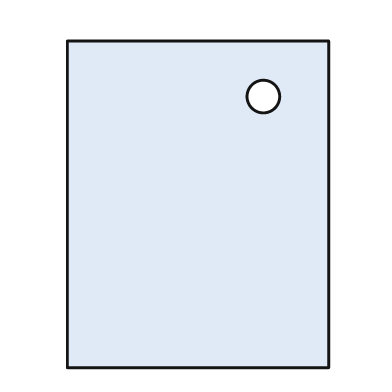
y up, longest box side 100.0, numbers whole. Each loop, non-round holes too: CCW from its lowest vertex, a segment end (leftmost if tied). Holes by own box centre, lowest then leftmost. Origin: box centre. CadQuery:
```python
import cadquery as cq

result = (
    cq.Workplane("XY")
    .moveTo(-40.0, -50.0)
    .lineTo(40.0, -50.0)
    .lineTo(40.0, 50.0)
    .lineTo(-40.0, 50.0)
    .close()
    .moveTo(20.0, 33.0)
    .circle(5.0)
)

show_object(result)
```